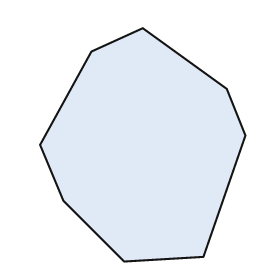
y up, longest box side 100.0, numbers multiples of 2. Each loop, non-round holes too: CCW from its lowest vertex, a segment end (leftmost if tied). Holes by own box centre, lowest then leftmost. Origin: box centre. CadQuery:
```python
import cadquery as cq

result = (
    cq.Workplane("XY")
    .moveTo(-8.0, -50.0)
    .lineTo(26.0, -48.0)
    .lineTo(44.0, 4.0)
    .lineTo(36.0, 24.0)
    .lineTo(0.0, 50.0)
    .lineTo(-22.0, 40.0)
    .lineTo(-44.0, 0.0)
    .lineTo(-34.0, -24.0)
    .close()
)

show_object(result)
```